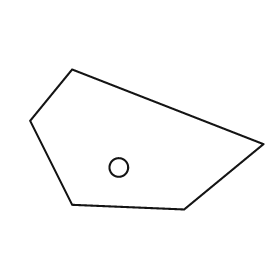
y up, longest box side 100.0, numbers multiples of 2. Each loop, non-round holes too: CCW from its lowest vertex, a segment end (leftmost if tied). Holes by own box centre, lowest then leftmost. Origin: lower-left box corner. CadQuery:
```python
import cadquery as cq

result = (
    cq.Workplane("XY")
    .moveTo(66.0, 0.0)
    .lineTo(100.0, 28.0)
    .lineTo(18.0, 60.0)
    .lineTo(0.0, 38.0)
    .lineTo(18.0, 2.0)
    .close()
    .moveTo(38.0, 18.0)
    .circle(4.0)
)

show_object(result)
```